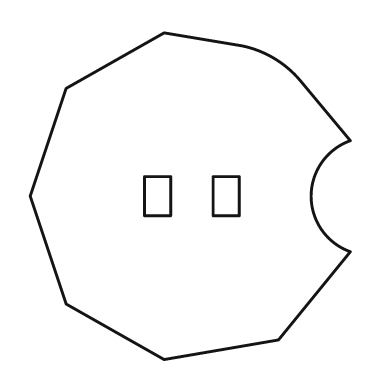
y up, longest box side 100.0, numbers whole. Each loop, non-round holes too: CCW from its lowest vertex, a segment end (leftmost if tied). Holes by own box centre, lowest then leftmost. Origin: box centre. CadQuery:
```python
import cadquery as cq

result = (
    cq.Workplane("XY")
    .moveTo(-8.0, -50.0)
    .lineTo(27.0, -44.0)
    .lineTo(49.0, -17.0)
    .threePointArc((37.0, 0.0), (49.0, 17.0))
    .lineTo(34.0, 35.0)
    .threePointArc((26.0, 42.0), (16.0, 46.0))
    .lineTo(-8.0, 50.0)
    .lineTo(-38.0, 33.0)
    .lineTo(-49.0, 0.0)
    .lineTo(-38.0, -33.0)
    .close()
    .moveTo(-14.0, -6.0)
    .lineTo(-6.0, -6.0)
    .lineTo(-6.0, 6.0)
    .lineTo(-14.0, 6.0)
    .close()
    .moveTo(7.0, -6.0)
    .lineTo(15.0, -6.0)
    .lineTo(15.0, 6.0)
    .lineTo(7.0, 6.0)
    .close()
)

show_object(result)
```